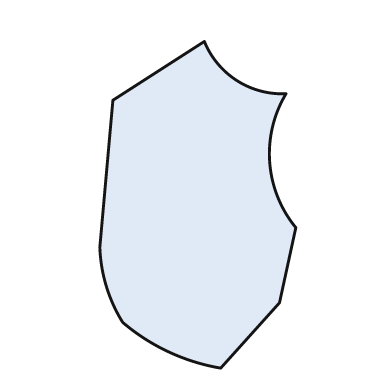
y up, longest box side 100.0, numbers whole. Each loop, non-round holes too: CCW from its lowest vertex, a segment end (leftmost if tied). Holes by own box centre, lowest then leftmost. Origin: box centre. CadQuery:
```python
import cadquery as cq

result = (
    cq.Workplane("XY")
    .moveTo(7.0, -50.0)
    .lineTo(25.0, -30.0)
    .lineTo(30.0, -7.0)
    .threePointArc((22.0, 13.0), (27.0, 34.0))
    .threePointArc((12.0, 38.0), (2.0, 50.0))
    .lineTo(-26.0, 32.0)
    .lineTo(-30.0, -13.0)
    .threePointArc((-28.0, -25.0), (-23.0, -36.0))
    .threePointArc((-9.0, -45.0), (7.0, -50.0))
    .close()
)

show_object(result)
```